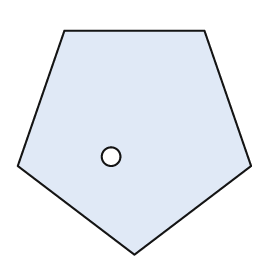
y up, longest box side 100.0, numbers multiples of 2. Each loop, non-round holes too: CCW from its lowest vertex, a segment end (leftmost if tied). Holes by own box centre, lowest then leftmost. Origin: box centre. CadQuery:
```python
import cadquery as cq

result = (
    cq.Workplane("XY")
    .moveTo(0.0, -48.0)
    .lineTo(50.0, -10.0)
    .lineTo(30.0, 48.0)
    .lineTo(-30.0, 48.0)
    .lineTo(-50.0, -10.0)
    .close()
    .moveTo(-10.0, -6.0)
    .circle(4.0)
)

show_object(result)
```